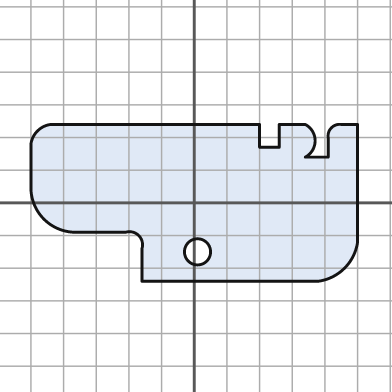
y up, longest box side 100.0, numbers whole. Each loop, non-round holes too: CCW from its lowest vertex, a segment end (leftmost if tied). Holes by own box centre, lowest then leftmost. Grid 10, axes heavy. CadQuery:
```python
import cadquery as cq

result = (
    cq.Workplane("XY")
    .moveTo(-16.0, -24.0)
    .lineTo(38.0, -24.0)
    .threePointArc((46.0, -20.0), (50.0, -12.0))
    .lineTo(50.0, 24.0)
    .lineTo(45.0, 24.0)
    .threePointArc((42.0, 23.0), (41.0, 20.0))
    .lineTo(41.0, 14.0)
    .lineTo(34.0, 14.0)
    .threePointArc((37.0, 19.0), (34.0, 24.0))
    .lineTo(26.0, 24.0)
    .lineTo(26.0, 17.0)
    .lineTo(20.0, 17.0)
    .lineTo(20.0, 24.0)
    .lineTo(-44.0, 24.0)
    .threePointArc((-48.0, 22.0), (-50.0, 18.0))
    .lineTo(-50.0, 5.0)
    .threePointArc((-46.0, -5.0), (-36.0, -9.0))
    .lineTo(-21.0, -9.0)
    .threePointArc((-17.0, -10.0), (-16.0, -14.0))
    .close()
    .moveTo(1.0, -15.0)
    .circle(4.0)
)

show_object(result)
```